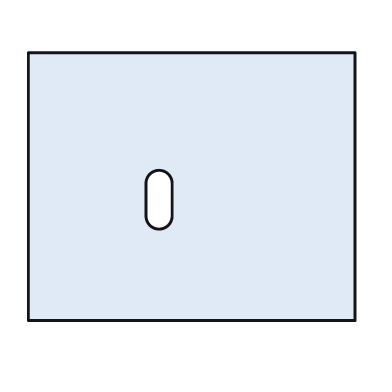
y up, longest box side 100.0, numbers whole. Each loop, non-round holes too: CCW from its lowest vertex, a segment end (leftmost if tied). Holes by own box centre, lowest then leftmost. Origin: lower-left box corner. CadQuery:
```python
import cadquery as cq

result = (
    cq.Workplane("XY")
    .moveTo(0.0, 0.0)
    .lineTo(100.0, 0.0)
    .lineTo(100.0, 82.0)
    .lineTo(0.0, 82.0)
    .close()
    .moveTo(36.0, 32.0)
    .threePointArc((40.0, 28.0), (44.0, 32.0))
    .lineTo(44.0, 42.0)
    .threePointArc((40.0, 46.0), (36.0, 42.0))
    .close()
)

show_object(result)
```